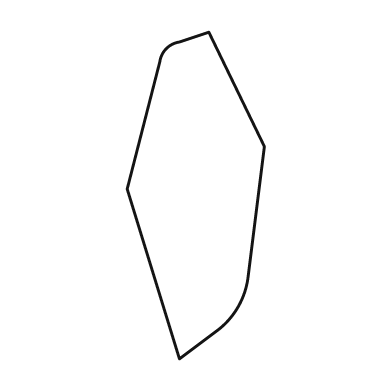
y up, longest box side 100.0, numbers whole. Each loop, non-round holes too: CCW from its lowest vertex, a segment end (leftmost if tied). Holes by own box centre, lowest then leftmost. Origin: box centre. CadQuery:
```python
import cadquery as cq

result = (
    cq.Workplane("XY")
    .moveTo(-5.0, -50.0)
    .lineTo(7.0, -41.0)
    .threePointArc((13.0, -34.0), (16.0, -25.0))
    .lineTo(21.0, 15.0)
    .lineTo(4.0, 50.0)
    .lineTo(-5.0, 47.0)
    .threePointArc((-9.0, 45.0), (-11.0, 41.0))
    .lineTo(-21.0, 2.0)
    .close()
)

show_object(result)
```